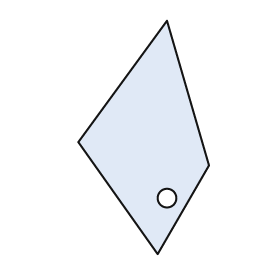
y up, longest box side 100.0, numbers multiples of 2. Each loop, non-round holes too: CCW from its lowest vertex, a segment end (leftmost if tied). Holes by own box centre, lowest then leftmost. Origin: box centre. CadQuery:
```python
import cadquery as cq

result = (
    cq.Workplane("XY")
    .moveTo(6.0, -50.0)
    .lineTo(28.0, -12.0)
    .lineTo(10.0, 50.0)
    .lineTo(-28.0, -2.0)
    .close()
    .moveTo(10.0, -26.0)
    .circle(4.0)
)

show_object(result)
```